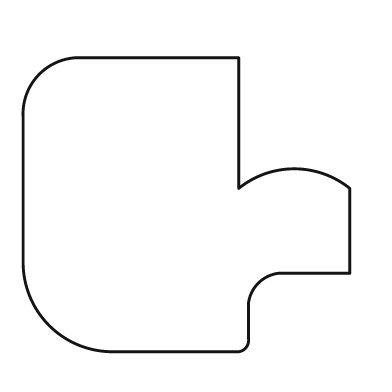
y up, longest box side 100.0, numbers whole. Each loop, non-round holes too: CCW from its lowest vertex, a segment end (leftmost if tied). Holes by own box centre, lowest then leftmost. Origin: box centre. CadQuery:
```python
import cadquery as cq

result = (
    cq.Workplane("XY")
    .moveTo(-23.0, -45.0)
    .lineTo(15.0, -45.0)
    .threePointArc((18.0, -44.0), (19.0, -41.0))
    .lineTo(19.0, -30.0)
    .threePointArc((22.0, -24.0), (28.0, -21.0))
    .lineTo(50.0, -21.0)
    .lineTo(50.0, 5.0)
    .threePointArc((33.0, 11.0), (16.0, 5.0))
    .lineTo(16.0, 45.0)
    .lineTo(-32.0, 45.0)
    .threePointArc((-45.0, 40.0), (-50.0, 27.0))
    .lineTo(-50.0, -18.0)
    .threePointArc((-42.0, -37.0), (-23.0, -45.0))
    .close()
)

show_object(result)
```